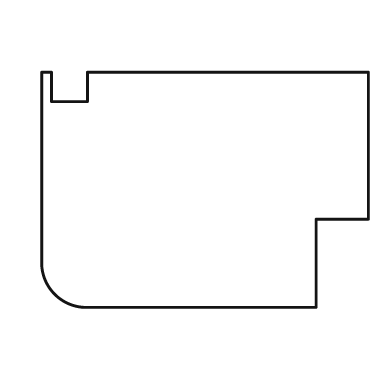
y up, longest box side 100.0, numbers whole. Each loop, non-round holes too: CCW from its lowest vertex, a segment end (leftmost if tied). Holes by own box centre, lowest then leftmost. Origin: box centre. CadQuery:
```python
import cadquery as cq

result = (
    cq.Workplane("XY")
    .moveTo(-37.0, -36.0)
    .lineTo(34.0, -36.0)
    .lineTo(34.0, -9.0)
    .lineTo(50.0, -9.0)
    .lineTo(50.0, 36.0)
    .lineTo(-36.0, 36.0)
    .lineTo(-36.0, 27.0)
    .lineTo(-47.0, 27.0)
    .lineTo(-47.0, 36.0)
    .lineTo(-50.0, 36.0)
    .lineTo(-50.0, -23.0)
    .threePointArc((-46.0, -32.0), (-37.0, -36.0))
    .close()
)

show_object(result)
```